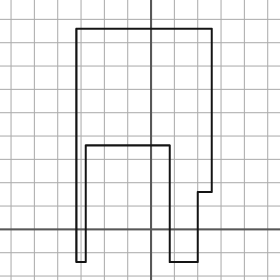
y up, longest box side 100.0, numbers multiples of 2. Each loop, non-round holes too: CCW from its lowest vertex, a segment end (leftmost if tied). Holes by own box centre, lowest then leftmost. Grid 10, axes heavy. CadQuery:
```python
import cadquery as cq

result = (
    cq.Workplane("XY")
    .moveTo(-32.0, -14.0)
    .lineTo(-28.0, -14.0)
    .lineTo(-28.0, 36.0)
    .lineTo(8.0, 36.0)
    .lineTo(8.0, -14.0)
    .lineTo(20.0, -14.0)
    .lineTo(20.0, 16.0)
    .lineTo(26.0, 16.0)
    .lineTo(26.0, 86.0)
    .lineTo(-32.0, 86.0)
    .close()
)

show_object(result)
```